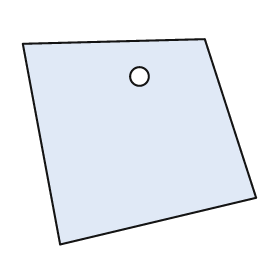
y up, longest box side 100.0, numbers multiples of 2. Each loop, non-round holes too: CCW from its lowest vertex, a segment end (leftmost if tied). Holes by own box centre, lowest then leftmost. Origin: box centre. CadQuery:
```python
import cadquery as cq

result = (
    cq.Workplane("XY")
    .moveTo(-34.0, -44.0)
    .lineTo(50.0, -24.0)
    .lineTo(28.0, 44.0)
    .lineTo(-50.0, 42.0)
    .close()
    .moveTo(0.0, 28.0)
    .circle(4.0)
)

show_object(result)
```